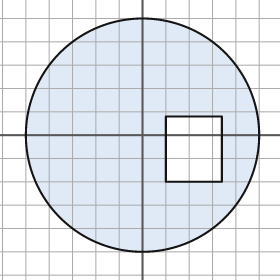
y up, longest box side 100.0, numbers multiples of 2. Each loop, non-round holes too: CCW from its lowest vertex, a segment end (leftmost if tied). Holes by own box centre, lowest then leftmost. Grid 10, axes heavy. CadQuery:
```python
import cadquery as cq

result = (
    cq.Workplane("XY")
    .moveTo(0.0, 0.0)
    .circle(50.0)
    .moveTo(10.0, -20.0)
    .lineTo(34.0, -20.0)
    .lineTo(34.0, 8.0)
    .lineTo(10.0, 8.0)
    .close()
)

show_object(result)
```